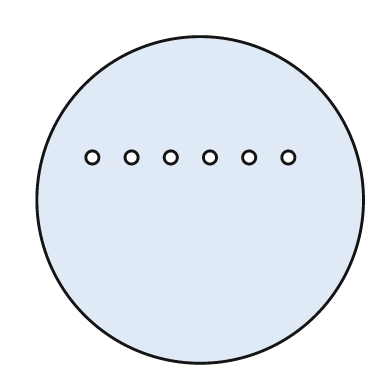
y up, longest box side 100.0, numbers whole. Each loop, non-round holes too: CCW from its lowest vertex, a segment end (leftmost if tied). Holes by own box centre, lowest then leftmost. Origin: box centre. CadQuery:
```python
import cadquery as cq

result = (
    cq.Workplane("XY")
    .moveTo(0.0, 0.0)
    .circle(50.0)
    .moveTo(-33.0, 13.0)
    .circle(2.0)
    .moveTo(-21.0, 13.0)
    .circle(2.0)
    .moveTo(-9.0, 13.0)
    .circle(2.0)
    .moveTo(3.0, 13.0)
    .circle(2.0)
    .moveTo(15.0, 13.0)
    .circle(2.0)
    .moveTo(27.0, 13.0)
    .circle(2.0)
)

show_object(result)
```